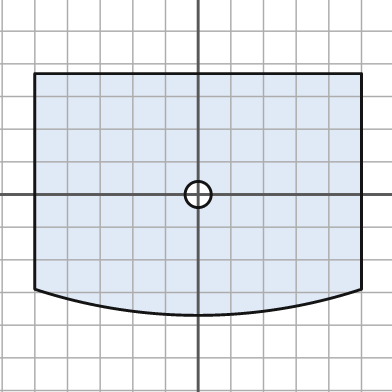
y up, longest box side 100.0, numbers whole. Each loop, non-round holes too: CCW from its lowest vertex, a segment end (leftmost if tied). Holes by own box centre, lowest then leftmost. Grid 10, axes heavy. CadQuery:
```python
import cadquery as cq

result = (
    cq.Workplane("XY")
    .moveTo(-50.0, -29.0)
    .threePointArc((0.0, -37.0), (50.0, -29.0))
    .lineTo(50.0, 37.0)
    .lineTo(-50.0, 37.0)
    .close()
    .moveTo(0.0, 0.0)
    .circle(4.0)
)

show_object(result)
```